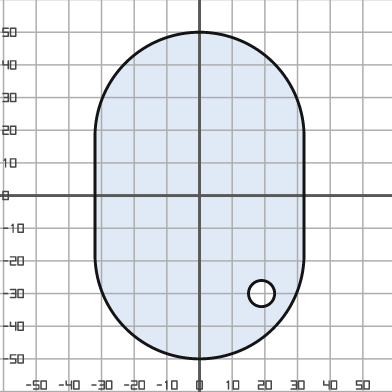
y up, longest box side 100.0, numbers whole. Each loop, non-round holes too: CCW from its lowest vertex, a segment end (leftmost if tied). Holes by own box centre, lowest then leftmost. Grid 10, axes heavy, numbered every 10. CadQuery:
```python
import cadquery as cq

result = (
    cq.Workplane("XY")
    .moveTo(-32.0, -18.0)
    .threePointArc((0.0, -50.0), (32.0, -18.0))
    .lineTo(32.0, 18.0)
    .threePointArc((0.0, 50.0), (-32.0, 18.0))
    .close()
    .moveTo(19.0, -30.0)
    .circle(4.0)
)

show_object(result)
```